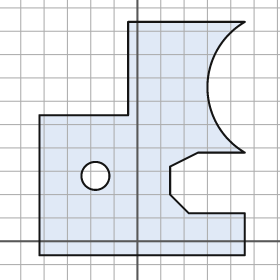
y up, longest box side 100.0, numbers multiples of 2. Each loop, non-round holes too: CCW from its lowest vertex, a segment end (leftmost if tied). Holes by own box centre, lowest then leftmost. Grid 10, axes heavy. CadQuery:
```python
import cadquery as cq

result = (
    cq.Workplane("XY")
    .moveTo(-42.0, -6.0)
    .lineTo(46.0, -6.0)
    .lineTo(46.0, 12.0)
    .lineTo(22.0, 12.0)
    .lineTo(14.0, 20.0)
    .lineTo(14.0, 32.0)
    .lineTo(26.0, 38.0)
    .lineTo(46.0, 38.0)
    .threePointArc((30.0, 66.0), (46.0, 94.0))
    .lineTo(-4.0, 94.0)
    .lineTo(-4.0, 54.0)
    .lineTo(-42.0, 54.0)
    .close()
    .moveTo(-18.0, 28.0)
    .circle(6.0)
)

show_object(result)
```